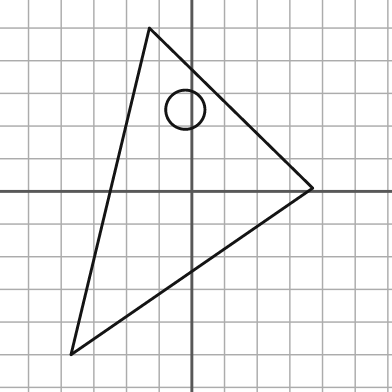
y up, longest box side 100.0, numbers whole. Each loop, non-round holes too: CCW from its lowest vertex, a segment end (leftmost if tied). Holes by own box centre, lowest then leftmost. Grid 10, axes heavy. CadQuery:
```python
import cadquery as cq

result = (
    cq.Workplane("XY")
    .moveTo(-37.0, -50.0)
    .lineTo(37.0, 1.0)
    .lineTo(-13.0, 50.0)
    .close()
    .moveTo(-2.0, 25.0)
    .circle(6.0)
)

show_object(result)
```